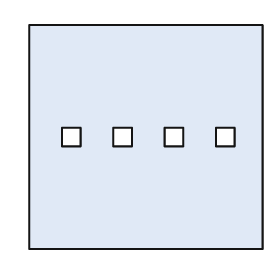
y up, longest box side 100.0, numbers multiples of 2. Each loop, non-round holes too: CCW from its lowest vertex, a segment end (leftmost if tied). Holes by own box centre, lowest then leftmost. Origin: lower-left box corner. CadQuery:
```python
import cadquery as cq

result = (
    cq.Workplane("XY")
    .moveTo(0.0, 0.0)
    .lineTo(100.0, 0.0)
    .lineTo(100.0, 96.0)
    .lineTo(0.0, 96.0)
    .close()
    .moveTo(14.0, 44.0)
    .lineTo(22.0, 44.0)
    .lineTo(22.0, 52.0)
    .lineTo(14.0, 52.0)
    .close()
    .moveTo(36.0, 44.0)
    .lineTo(44.0, 44.0)
    .lineTo(44.0, 52.0)
    .lineTo(36.0, 52.0)
    .close()
    .moveTo(58.0, 44.0)
    .lineTo(66.0, 44.0)
    .lineTo(66.0, 52.0)
    .lineTo(58.0, 52.0)
    .close()
    .moveTo(80.0, 44.0)
    .lineTo(88.0, 44.0)
    .lineTo(88.0, 52.0)
    .lineTo(80.0, 52.0)
    .close()
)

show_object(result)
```